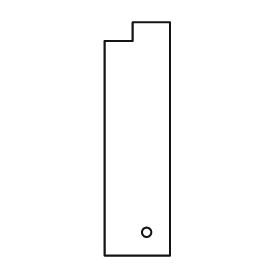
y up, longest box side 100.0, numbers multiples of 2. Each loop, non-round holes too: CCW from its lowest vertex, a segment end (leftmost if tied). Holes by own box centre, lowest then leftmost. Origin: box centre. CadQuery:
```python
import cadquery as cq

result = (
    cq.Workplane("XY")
    .moveTo(-14.0, -50.0)
    .lineTo(14.0, -50.0)
    .lineTo(14.0, 50.0)
    .lineTo(-2.0, 50.0)
    .lineTo(-2.0, 42.0)
    .lineTo(-14.0, 42.0)
    .close()
    .moveTo(4.0, -40.0)
    .circle(2.0)
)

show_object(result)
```